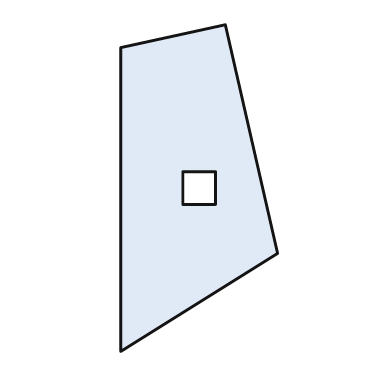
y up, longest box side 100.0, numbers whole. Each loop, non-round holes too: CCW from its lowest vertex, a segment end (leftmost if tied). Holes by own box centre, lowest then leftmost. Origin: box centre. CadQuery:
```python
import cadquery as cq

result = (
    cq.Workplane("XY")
    .moveTo(-24.0, -50.0)
    .lineTo(24.0, -20.0)
    .lineTo(8.0, 50.0)
    .lineTo(-24.0, 43.0)
    .close()
    .moveTo(-5.0, -5.0)
    .lineTo(5.0, -5.0)
    .lineTo(5.0, 5.0)
    .lineTo(-5.0, 5.0)
    .close()
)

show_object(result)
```